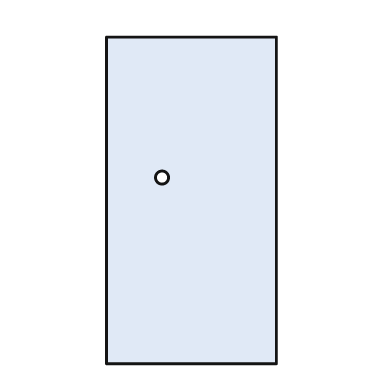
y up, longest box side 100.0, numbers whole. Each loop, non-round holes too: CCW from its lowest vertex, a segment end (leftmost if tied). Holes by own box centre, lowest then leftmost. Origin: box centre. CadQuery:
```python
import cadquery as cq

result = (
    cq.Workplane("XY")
    .moveTo(-26.0, -50.0)
    .lineTo(26.0, -50.0)
    .lineTo(26.0, 50.0)
    .lineTo(-26.0, 50.0)
    .close()
    .moveTo(-9.0, 7.0)
    .circle(2.0)
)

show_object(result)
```